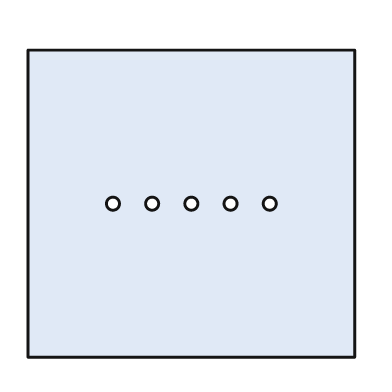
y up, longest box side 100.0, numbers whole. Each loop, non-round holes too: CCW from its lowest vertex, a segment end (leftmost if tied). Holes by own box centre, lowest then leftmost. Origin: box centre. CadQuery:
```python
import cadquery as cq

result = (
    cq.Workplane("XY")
    .moveTo(-50.0, -47.0)
    .lineTo(50.0, -47.0)
    .lineTo(50.0, 47.0)
    .lineTo(-50.0, 47.0)
    .close()
    .moveTo(-24.0, 0.0)
    .circle(2.0)
    .moveTo(-12.0, 0.0)
    .circle(2.0)
    .moveTo(0.0, 0.0)
    .circle(2.0)
    .moveTo(12.0, 0.0)
    .circle(2.0)
    .moveTo(24.0, 0.0)
    .circle(2.0)
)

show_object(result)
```